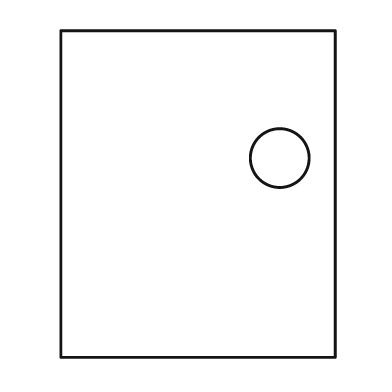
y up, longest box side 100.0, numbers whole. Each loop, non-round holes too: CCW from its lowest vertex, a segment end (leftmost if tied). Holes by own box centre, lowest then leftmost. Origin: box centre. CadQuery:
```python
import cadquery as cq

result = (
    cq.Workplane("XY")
    .moveTo(-42.0, -50.0)
    .lineTo(42.0, -50.0)
    .lineTo(42.0, 50.0)
    .lineTo(-42.0, 50.0)
    .close()
    .moveTo(25.0, 11.0)
    .circle(9.0)
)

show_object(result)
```